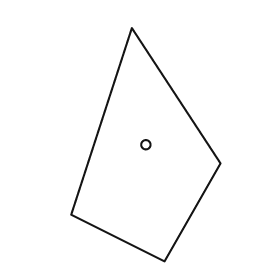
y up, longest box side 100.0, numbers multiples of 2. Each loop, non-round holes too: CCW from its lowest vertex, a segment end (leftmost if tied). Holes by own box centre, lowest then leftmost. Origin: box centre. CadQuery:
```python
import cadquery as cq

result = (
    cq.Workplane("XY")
    .moveTo(8.0, -50.0)
    .lineTo(32.0, -8.0)
    .lineTo(-6.0, 50.0)
    .lineTo(-32.0, -30.0)
    .close()
    .moveTo(0.0, 0.0)
    .circle(2.0)
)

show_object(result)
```